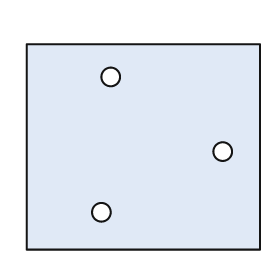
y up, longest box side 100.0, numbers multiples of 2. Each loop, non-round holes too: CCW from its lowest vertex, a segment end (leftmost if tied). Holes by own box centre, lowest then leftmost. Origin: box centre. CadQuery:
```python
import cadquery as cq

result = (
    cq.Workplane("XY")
    .moveTo(-50.0, -44.0)
    .lineTo(50.0, -44.0)
    .lineTo(50.0, 44.0)
    .lineTo(-50.0, 44.0)
    .close()
    .moveTo(-18.0, -28.0)
    .circle(4.0)
    .moveTo(34.0, -2.0)
    .circle(4.0)
    .moveTo(-14.0, 30.0)
    .circle(4.0)
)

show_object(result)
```